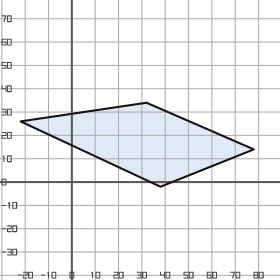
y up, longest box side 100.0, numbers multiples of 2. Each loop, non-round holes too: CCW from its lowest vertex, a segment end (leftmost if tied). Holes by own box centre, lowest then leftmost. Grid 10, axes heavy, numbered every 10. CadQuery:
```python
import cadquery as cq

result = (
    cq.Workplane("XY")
    .moveTo(38.0, -2.0)
    .lineTo(78.0, 14.0)
    .lineTo(32.0, 34.0)
    .lineTo(-22.0, 26.0)
    .close()
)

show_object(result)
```